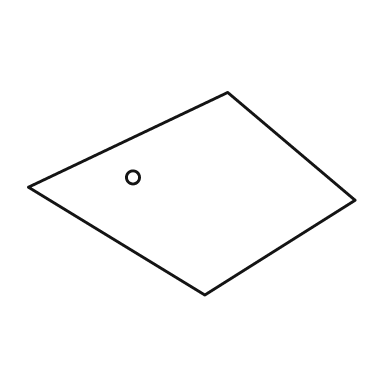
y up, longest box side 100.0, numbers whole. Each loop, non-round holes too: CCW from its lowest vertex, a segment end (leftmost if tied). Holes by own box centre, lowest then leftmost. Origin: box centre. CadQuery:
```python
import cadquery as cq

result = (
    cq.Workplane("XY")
    .moveTo(4.0, -31.0)
    .lineTo(50.0, -2.0)
    .lineTo(11.0, 31.0)
    .lineTo(-50.0, 2.0)
    .close()
    .moveTo(-18.0, 5.0)
    .circle(2.0)
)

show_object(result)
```